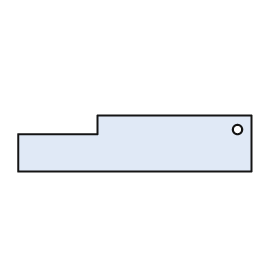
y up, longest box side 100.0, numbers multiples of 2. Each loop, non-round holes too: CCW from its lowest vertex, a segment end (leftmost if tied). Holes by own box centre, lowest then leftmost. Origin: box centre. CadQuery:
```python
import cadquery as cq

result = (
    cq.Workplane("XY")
    .moveTo(-50.0, -12.0)
    .lineTo(50.0, -12.0)
    .lineTo(50.0, 12.0)
    .lineTo(-16.0, 12.0)
    .lineTo(-16.0, 4.0)
    .lineTo(-50.0, 4.0)
    .close()
    .moveTo(44.0, 6.0)
    .circle(2.0)
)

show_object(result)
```